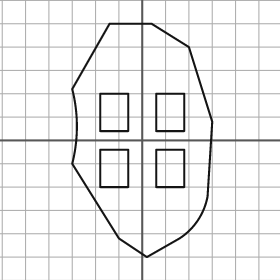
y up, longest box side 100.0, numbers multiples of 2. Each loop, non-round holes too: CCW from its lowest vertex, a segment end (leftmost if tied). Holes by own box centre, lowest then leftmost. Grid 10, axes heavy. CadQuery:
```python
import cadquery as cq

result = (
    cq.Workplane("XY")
    .moveTo(2.0, -50.0)
    .lineTo(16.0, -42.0)
    .threePointArc((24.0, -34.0), (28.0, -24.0))
    .lineTo(30.0, 8.0)
    .lineTo(20.0, 40.0)
    .lineTo(4.0, 50.0)
    .lineTo(-14.0, 50.0)
    .lineTo(-30.0, 22.0)
    .threePointArc((-28.0, 6.0), (-30.0, -10.0))
    .lineTo(-10.0, -42.0)
    .close()
    .moveTo(-18.0, -20.0)
    .lineTo(-6.0, -20.0)
    .lineTo(-6.0, -4.0)
    .lineTo(-18.0, -4.0)
    .close()
    .moveTo(6.0, -20.0)
    .lineTo(18.0, -20.0)
    .lineTo(18.0, -4.0)
    .lineTo(6.0, -4.0)
    .close()
    .moveTo(-18.0, 4.0)
    .lineTo(-6.0, 4.0)
    .lineTo(-6.0, 20.0)
    .lineTo(-18.0, 20.0)
    .close()
    .moveTo(6.0, 4.0)
    .lineTo(18.0, 4.0)
    .lineTo(18.0, 20.0)
    .lineTo(6.0, 20.0)
    .close()
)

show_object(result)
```